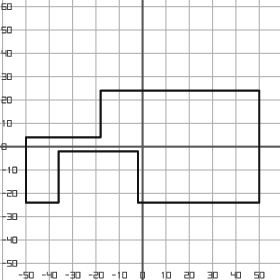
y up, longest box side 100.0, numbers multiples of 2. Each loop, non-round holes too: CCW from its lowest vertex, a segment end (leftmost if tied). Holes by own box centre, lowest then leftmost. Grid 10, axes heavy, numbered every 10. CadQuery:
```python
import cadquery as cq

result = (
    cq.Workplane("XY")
    .moveTo(-50.0, -24.0)
    .lineTo(-36.0, -24.0)
    .lineTo(-36.0, -2.0)
    .lineTo(-2.0, -2.0)
    .lineTo(-2.0, -24.0)
    .lineTo(50.0, -24.0)
    .lineTo(50.0, 24.0)
    .lineTo(-18.0, 24.0)
    .lineTo(-18.0, 4.0)
    .lineTo(-50.0, 4.0)
    .close()
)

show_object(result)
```